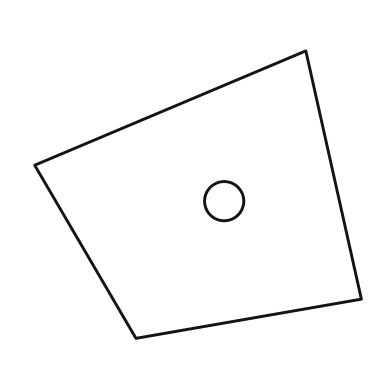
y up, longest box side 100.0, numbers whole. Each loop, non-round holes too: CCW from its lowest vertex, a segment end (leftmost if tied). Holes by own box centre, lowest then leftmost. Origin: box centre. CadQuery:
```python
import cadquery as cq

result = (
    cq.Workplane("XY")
    .moveTo(-19.0, -44.0)
    .lineTo(50.0, -32.0)
    .lineTo(33.0, 44.0)
    .lineTo(-50.0, 9.0)
    .close()
    .moveTo(8.0, -2.0)
    .circle(6.0)
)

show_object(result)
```